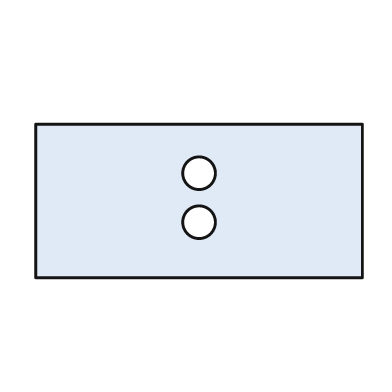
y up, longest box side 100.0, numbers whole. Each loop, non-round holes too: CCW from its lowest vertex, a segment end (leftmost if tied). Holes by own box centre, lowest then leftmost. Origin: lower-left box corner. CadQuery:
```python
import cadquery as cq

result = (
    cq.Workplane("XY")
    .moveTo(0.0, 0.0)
    .lineTo(100.0, 0.0)
    .lineTo(100.0, 47.0)
    .lineTo(0.0, 47.0)
    .close()
    .moveTo(50.0, 17.0)
    .circle(5.0)
    .moveTo(50.0, 32.0)
    .circle(5.0)
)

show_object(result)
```